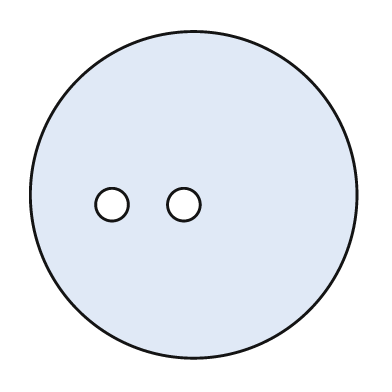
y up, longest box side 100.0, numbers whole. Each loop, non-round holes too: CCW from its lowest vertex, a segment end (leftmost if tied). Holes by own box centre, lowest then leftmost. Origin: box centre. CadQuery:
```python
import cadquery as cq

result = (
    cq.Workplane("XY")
    .moveTo(0.0, 0.0)
    .circle(50.0)
    .moveTo(-25.0, -3.0)
    .circle(5.0)
    .moveTo(-3.0, -3.0)
    .circle(5.0)
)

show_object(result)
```